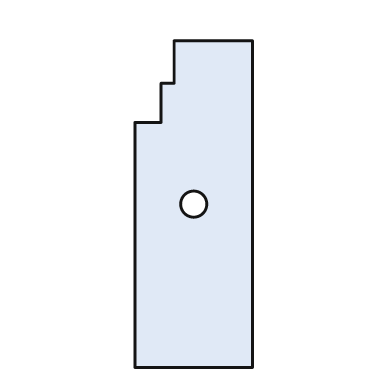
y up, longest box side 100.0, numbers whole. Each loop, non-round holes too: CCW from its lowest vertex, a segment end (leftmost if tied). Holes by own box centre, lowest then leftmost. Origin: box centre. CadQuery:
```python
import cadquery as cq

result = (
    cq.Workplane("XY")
    .moveTo(-18.0, -50.0)
    .lineTo(18.0, -50.0)
    .lineTo(18.0, 50.0)
    .lineTo(-6.0, 50.0)
    .lineTo(-6.0, 37.0)
    .lineTo(-10.0, 37.0)
    .lineTo(-10.0, 25.0)
    .lineTo(-18.0, 25.0)
    .close()
    .moveTo(0.0, 0.0)
    .circle(4.0)
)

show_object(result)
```